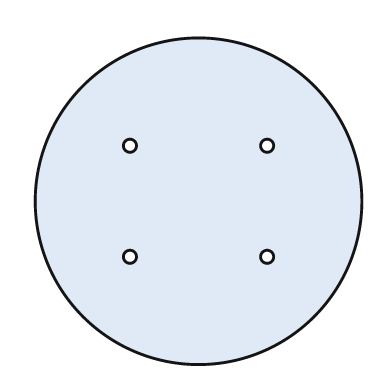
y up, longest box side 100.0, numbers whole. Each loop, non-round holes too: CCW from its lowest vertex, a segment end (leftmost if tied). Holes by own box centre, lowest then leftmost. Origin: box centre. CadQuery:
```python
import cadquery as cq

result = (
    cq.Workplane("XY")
    .moveTo(0.0, 0.0)
    .circle(50.0)
    .moveTo(-21.0, -17.0)
    .circle(2.0)
    .moveTo(21.0, -17.0)
    .circle(2.0)
    .moveTo(-21.0, 17.0)
    .circle(2.0)
    .moveTo(21.0, 17.0)
    .circle(2.0)
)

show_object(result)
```